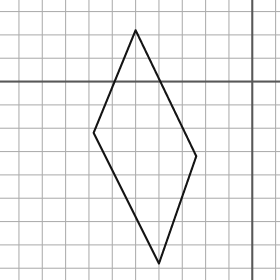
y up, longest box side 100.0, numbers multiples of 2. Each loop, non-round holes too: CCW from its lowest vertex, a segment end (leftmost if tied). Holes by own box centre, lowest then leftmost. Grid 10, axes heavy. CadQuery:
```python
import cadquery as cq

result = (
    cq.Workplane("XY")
    .moveTo(-40.0, -78.0)
    .lineTo(-24.0, -32.0)
    .lineTo(-50.0, 22.0)
    .lineTo(-68.0, -22.0)
    .close()
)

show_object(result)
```